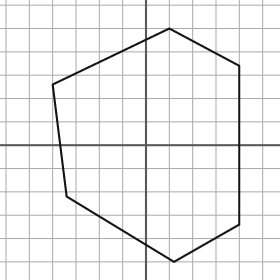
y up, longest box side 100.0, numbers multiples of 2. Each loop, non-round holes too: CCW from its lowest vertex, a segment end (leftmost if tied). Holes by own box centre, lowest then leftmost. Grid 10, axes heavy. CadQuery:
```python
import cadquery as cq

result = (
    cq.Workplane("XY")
    .moveTo(12.0, -50.0)
    .lineTo(40.0, -34.0)
    .lineTo(40.0, 34.0)
    .lineTo(10.0, 50.0)
    .lineTo(-40.0, 26.0)
    .lineTo(-34.0, -22.0)
    .close()
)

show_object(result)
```